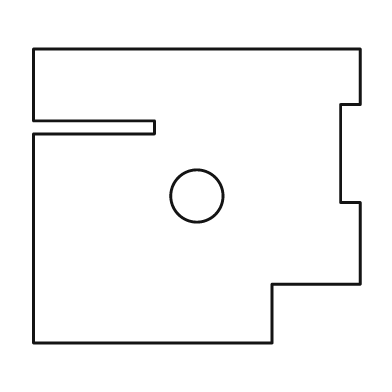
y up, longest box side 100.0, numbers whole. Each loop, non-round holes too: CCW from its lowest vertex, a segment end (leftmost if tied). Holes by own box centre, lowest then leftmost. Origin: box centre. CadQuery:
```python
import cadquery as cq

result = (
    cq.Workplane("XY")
    .moveTo(-50.0, -45.0)
    .lineTo(23.0, -45.0)
    .lineTo(23.0, -27.0)
    .lineTo(50.0, -27.0)
    .lineTo(50.0, -2.0)
    .lineTo(44.0, -2.0)
    .lineTo(44.0, 28.0)
    .lineTo(50.0, 28.0)
    .lineTo(50.0, 45.0)
    .lineTo(-50.0, 45.0)
    .lineTo(-50.0, 23.0)
    .lineTo(-13.0, 23.0)
    .lineTo(-13.0, 19.0)
    .lineTo(-50.0, 19.0)
    .close()
    .moveTo(0.0, 0.0)
    .circle(8.0)
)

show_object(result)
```